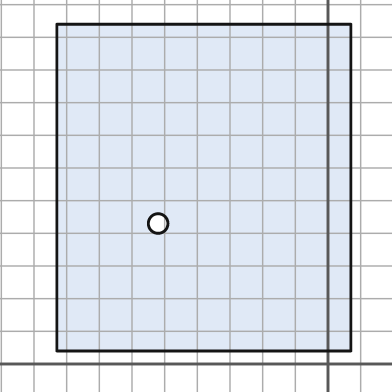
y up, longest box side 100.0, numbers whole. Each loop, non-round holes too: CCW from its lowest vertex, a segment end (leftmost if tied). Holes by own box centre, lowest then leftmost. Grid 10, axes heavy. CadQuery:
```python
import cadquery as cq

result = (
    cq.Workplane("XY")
    .moveTo(-83.0, 4.0)
    .lineTo(7.0, 4.0)
    .lineTo(7.0, 104.0)
    .lineTo(-83.0, 104.0)
    .close()
    .moveTo(-52.0, 43.0)
    .circle(3.0)
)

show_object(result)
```